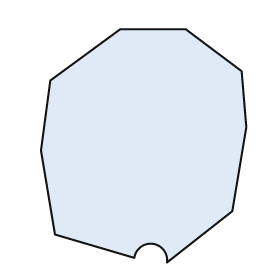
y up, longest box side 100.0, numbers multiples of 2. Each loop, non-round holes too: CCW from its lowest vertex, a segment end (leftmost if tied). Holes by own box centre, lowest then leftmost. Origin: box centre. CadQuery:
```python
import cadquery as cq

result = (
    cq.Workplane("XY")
    .moveTo(10.0, -50.0)
    .lineTo(38.0, -28.0)
    .lineTo(44.0, 8.0)
    .lineTo(42.0, 32.0)
    .lineTo(18.0, 50.0)
    .lineTo(-10.0, 50.0)
    .lineTo(-40.0, 28.0)
    .lineTo(-44.0, -2.0)
    .lineTo(-38.0, -38.0)
    .lineTo(-4.0, -48.0)
    .threePointArc((4.0, -42.0), (10.0, -50.0))
    .close()
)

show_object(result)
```